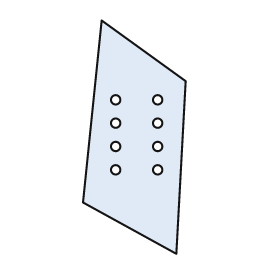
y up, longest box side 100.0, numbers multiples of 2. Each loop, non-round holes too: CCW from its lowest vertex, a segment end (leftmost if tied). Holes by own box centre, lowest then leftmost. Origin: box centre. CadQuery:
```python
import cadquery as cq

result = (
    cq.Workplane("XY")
    .moveTo(18.0, -50.0)
    .lineTo(22.0, 24.0)
    .lineTo(-14.0, 50.0)
    .lineTo(-22.0, -28.0)
    .close()
    .moveTo(-8.0, -14.0)
    .circle(2.0)
    .moveTo(10.0, -14.0)
    .circle(2.0)
    .moveTo(-8.0, -4.0)
    .circle(2.0)
    .moveTo(10.0, -4.0)
    .circle(2.0)
    .moveTo(-8.0, 6.0)
    .circle(2.0)
    .moveTo(10.0, 6.0)
    .circle(2.0)
    .moveTo(-8.0, 16.0)
    .circle(2.0)
    .moveTo(10.0, 16.0)
    .circle(2.0)
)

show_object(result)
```